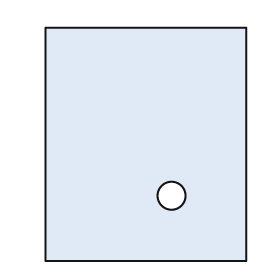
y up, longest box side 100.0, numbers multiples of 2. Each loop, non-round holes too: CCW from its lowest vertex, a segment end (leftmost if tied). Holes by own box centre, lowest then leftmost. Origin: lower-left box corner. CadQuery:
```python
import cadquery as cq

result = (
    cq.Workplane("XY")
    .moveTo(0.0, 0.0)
    .lineTo(86.0, 0.0)
    .lineTo(86.0, 100.0)
    .lineTo(0.0, 100.0)
    .close()
    .moveTo(54.0, 28.0)
    .circle(6.0)
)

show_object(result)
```